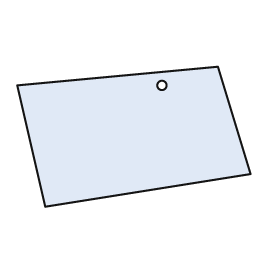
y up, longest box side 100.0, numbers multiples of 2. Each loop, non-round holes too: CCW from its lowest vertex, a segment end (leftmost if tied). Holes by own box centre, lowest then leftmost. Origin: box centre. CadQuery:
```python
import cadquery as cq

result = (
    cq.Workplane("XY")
    .moveTo(-38.0, -30.0)
    .lineTo(50.0, -16.0)
    .lineTo(36.0, 30.0)
    .lineTo(-50.0, 22.0)
    .close()
    .moveTo(12.0, 22.0)
    .circle(2.0)
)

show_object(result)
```